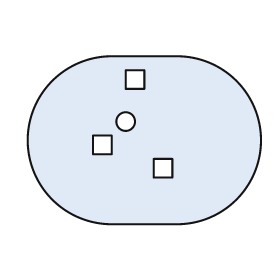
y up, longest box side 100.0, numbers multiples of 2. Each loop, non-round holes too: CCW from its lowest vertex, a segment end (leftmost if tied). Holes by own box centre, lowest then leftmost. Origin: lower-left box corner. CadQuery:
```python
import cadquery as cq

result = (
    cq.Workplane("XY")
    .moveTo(36.0, 0.0)
    .lineTo(64.0, 0.0)
    .threePointArc((100.0, 36.0), (64.0, 72.0))
    .lineTo(36.0, 72.0)
    .threePointArc((0.0, 36.0), (36.0, 0.0))
    .close()
    .moveTo(54.0, 20.0)
    .lineTo(62.0, 20.0)
    .lineTo(62.0, 28.0)
    .lineTo(54.0, 28.0)
    .close()
    .moveTo(28.0, 30.0)
    .lineTo(36.0, 30.0)
    .lineTo(36.0, 38.0)
    .lineTo(28.0, 38.0)
    .close()
    .moveTo(42.0, 44.0)
    .circle(4.0)
    .moveTo(42.0, 58.0)
    .lineTo(50.0, 58.0)
    .lineTo(50.0, 66.0)
    .lineTo(42.0, 66.0)
    .close()
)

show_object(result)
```